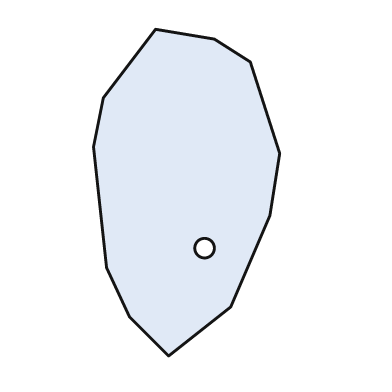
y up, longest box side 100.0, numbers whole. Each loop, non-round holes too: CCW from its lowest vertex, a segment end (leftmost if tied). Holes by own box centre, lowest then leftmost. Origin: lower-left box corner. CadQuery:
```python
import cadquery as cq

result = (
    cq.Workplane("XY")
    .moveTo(23.0, 0.0)
    .lineTo(42.0, 15.0)
    .lineTo(54.0, 43.0)
    .lineTo(57.0, 62.0)
    .lineTo(48.0, 90.0)
    .lineTo(37.0, 97.0)
    .lineTo(19.0, 100.0)
    .lineTo(3.0, 79.0)
    .lineTo(0.0, 64.0)
    .lineTo(4.0, 27.0)
    .lineTo(11.0, 12.0)
    .close()
    .moveTo(34.0, 33.0)
    .circle(3.0)
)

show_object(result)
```